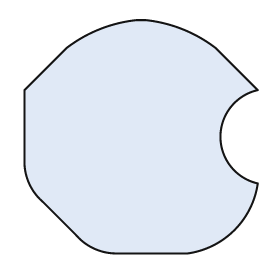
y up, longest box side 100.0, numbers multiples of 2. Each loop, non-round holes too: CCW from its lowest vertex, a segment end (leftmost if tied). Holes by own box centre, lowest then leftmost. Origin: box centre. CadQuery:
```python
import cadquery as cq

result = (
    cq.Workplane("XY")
    .moveTo(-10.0, -50.0)
    .lineTo(20.0, -50.0)
    .threePointArc((40.0, -40.0), (50.0, -20.0))
    .threePointArc((34.0, 0.0), (50.0, 20.0))
    .lineTo(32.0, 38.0)
    .threePointArc((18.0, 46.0), (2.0, 50.0))
    .lineTo(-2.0, 50.0)
    .threePointArc((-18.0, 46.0), (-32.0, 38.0))
    .lineTo(-50.0, 20.0)
    .lineTo(-50.0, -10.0)
    .threePointArc((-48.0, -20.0), (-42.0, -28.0))
    .lineTo(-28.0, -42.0)
    .threePointArc((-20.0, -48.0), (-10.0, -50.0))
    .close()
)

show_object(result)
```